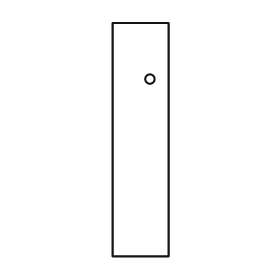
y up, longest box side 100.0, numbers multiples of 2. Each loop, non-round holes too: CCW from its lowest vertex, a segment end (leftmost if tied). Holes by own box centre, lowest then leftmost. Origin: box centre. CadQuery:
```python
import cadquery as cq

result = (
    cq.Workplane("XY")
    .moveTo(-12.0, -50.0)
    .lineTo(12.0, -50.0)
    .lineTo(12.0, 50.0)
    .lineTo(-12.0, 50.0)
    .close()
    .moveTo(4.0, 26.0)
    .circle(2.0)
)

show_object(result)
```